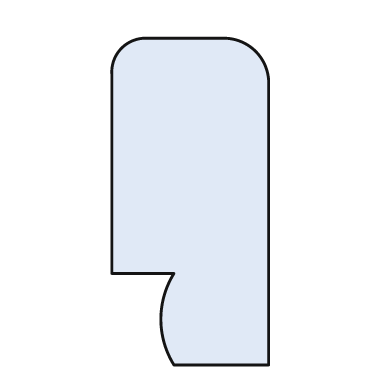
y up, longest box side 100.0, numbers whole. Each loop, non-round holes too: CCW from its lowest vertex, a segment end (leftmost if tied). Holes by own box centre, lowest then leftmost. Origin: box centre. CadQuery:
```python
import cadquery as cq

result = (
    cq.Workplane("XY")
    .moveTo(-5.0, -50.0)
    .lineTo(24.0, -50.0)
    .lineTo(24.0, 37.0)
    .threePointArc((20.0, 46.0), (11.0, 50.0))
    .lineTo(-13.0, 50.0)
    .threePointArc((-21.0, 47.0), (-24.0, 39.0))
    .lineTo(-24.0, -22.0)
    .lineTo(-5.0, -22.0)
    .threePointArc((-9.0, -36.0), (-5.0, -50.0))
    .close()
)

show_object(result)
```